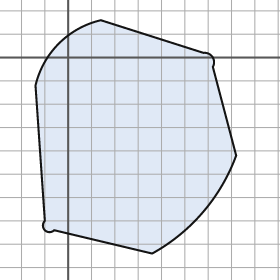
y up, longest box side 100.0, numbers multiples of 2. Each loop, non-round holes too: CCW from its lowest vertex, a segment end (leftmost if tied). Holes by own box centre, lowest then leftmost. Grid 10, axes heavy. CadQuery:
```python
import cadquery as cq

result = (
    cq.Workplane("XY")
    .moveTo(36.0, -84.0)
    .threePointArc((58.0, -66.0), (72.0, -42.0))
    .lineTo(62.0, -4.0)
    .threePointArc((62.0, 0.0), (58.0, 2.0))
    .lineTo(14.0, 16.0)
    .threePointArc((-4.0, 6.0), (-14.0, -12.0))
    .lineTo(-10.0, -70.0)
    .threePointArc((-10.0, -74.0), (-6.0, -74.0))
    .close()
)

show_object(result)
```